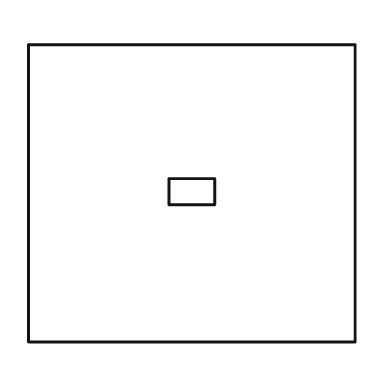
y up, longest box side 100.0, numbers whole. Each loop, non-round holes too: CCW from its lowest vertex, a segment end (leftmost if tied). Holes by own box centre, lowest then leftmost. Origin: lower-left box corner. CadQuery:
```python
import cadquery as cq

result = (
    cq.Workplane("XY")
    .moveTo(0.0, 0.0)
    .lineTo(100.0, 0.0)
    .lineTo(100.0, 91.0)
    .lineTo(0.0, 91.0)
    .close()
    .moveTo(43.0, 42.0)
    .lineTo(57.0, 42.0)
    .lineTo(57.0, 50.0)
    .lineTo(43.0, 50.0)
    .close()
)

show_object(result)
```